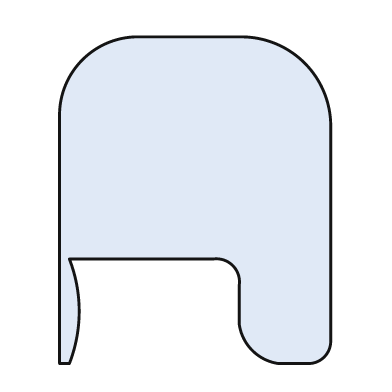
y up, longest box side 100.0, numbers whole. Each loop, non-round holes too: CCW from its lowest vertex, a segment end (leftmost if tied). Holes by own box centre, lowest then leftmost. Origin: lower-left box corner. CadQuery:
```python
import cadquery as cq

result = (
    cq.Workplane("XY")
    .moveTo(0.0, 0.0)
    .lineTo(3.0, 0.0)
    .threePointArc((6.0, 16.0), (3.0, 32.0))
    .lineTo(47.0, 32.0)
    .threePointArc((53.0, 30.0), (55.0, 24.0))
    .lineTo(55.0, 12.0)
    .threePointArc((59.0, 4.0), (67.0, 0.0))
    .lineTo(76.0, 0.0)
    .threePointArc((81.0, 2.0), (83.0, 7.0))
    .lineTo(83.0, 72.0)
    .threePointArc((75.0, 92.0), (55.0, 100.0))
    .lineTo(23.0, 100.0)
    .threePointArc((7.0, 93.0), (0.0, 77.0))
    .close()
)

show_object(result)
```